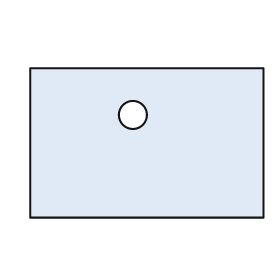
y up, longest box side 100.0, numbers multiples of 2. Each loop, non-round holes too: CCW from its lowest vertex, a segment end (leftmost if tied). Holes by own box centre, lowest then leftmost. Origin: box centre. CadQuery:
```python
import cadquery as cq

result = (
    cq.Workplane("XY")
    .moveTo(-50.0, -32.0)
    .lineTo(50.0, -32.0)
    .lineTo(50.0, 32.0)
    .lineTo(-50.0, 32.0)
    .close()
    .moveTo(-6.0, 12.0)
    .circle(6.0)
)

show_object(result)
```